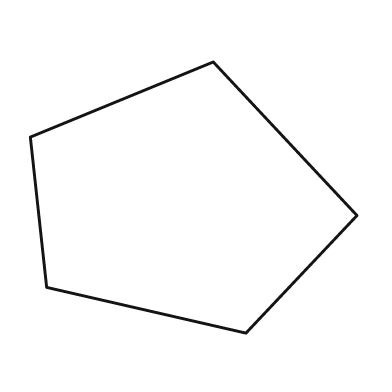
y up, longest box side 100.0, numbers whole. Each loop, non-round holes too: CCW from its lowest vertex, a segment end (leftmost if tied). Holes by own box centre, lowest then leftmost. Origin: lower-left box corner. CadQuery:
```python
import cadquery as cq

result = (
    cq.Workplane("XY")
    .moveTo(66.0, 0.0)
    .lineTo(100.0, 36.0)
    .lineTo(56.0, 83.0)
    .lineTo(0.0, 60.0)
    .lineTo(5.0, 14.0)
    .close()
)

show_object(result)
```